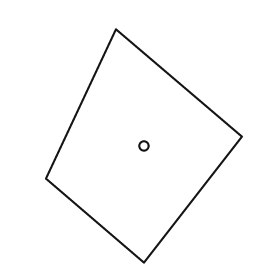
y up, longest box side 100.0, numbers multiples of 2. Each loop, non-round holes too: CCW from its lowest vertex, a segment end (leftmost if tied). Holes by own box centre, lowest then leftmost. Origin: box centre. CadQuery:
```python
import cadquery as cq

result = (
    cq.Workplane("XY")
    .moveTo(0.0, -50.0)
    .lineTo(42.0, 4.0)
    .lineTo(-12.0, 50.0)
    .lineTo(-42.0, -14.0)
    .close()
    .moveTo(0.0, 0.0)
    .circle(2.0)
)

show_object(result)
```